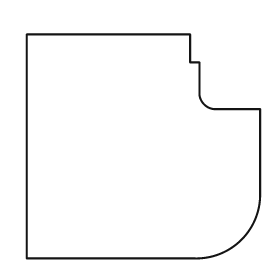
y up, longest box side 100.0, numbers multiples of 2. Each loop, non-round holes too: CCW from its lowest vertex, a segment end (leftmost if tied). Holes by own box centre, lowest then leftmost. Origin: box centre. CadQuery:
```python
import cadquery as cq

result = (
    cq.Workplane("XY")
    .moveTo(-50.0, -48.0)
    .lineTo(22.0, -48.0)
    .threePointArc((42.0, -40.0), (50.0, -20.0))
    .lineTo(50.0, 16.0)
    .lineTo(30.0, 16.0)
    .threePointArc((26.0, 18.0), (24.0, 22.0))
    .lineTo(24.0, 36.0)
    .lineTo(20.0, 36.0)
    .lineTo(20.0, 48.0)
    .lineTo(-50.0, 48.0)
    .close()
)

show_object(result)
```